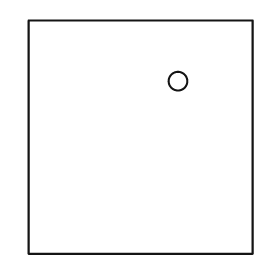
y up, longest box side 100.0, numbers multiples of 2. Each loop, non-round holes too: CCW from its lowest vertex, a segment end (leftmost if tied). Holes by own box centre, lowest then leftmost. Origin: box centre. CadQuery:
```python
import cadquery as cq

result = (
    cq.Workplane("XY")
    .moveTo(-48.0, -50.0)
    .lineTo(48.0, -50.0)
    .lineTo(48.0, 50.0)
    .lineTo(-48.0, 50.0)
    .close()
    .moveTo(16.0, 24.0)
    .circle(4.0)
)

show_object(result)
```